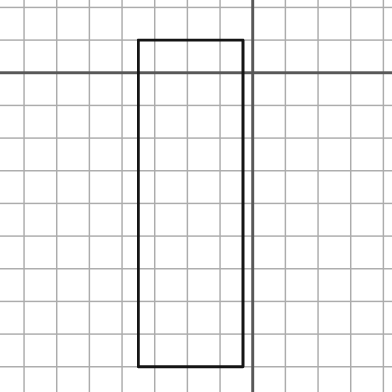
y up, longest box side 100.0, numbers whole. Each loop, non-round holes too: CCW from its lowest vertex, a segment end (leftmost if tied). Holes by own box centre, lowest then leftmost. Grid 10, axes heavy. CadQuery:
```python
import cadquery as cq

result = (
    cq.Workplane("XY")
    .moveTo(-35.0, -90.0)
    .lineTo(-3.0, -90.0)
    .lineTo(-3.0, 10.0)
    .lineTo(-35.0, 10.0)
    .close()
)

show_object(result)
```